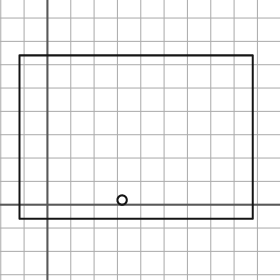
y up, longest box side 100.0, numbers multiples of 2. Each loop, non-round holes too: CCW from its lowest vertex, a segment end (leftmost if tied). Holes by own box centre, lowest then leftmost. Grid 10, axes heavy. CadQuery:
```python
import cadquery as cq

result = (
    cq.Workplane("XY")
    .moveTo(-12.0, -6.0)
    .lineTo(88.0, -6.0)
    .lineTo(88.0, 64.0)
    .lineTo(-12.0, 64.0)
    .close()
    .moveTo(32.0, 2.0)
    .circle(2.0)
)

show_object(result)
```